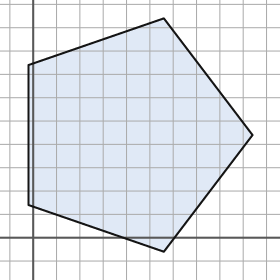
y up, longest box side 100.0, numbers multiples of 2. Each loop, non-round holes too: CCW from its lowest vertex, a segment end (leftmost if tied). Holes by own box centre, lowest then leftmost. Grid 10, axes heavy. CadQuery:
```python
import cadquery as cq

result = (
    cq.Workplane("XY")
    .moveTo(56.0, -6.0)
    .lineTo(94.0, 44.0)
    .lineTo(56.0, 94.0)
    .lineTo(-2.0, 74.0)
    .lineTo(-2.0, 14.0)
    .close()
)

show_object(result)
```